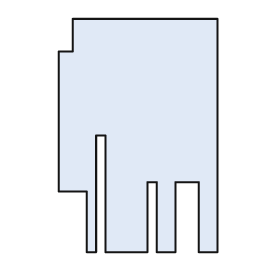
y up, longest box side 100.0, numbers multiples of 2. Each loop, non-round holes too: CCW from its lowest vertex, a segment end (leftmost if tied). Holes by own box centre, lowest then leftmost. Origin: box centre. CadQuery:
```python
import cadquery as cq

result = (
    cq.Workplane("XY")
    .moveTo(-22.0, -50.0)
    .lineTo(-18.0, -50.0)
    .lineTo(-18.0, 0.0)
    .lineTo(-14.0, 0.0)
    .lineTo(-14.0, -50.0)
    .lineTo(4.0, -50.0)
    .lineTo(4.0, -20.0)
    .lineTo(8.0, -20.0)
    .lineTo(8.0, -50.0)
    .lineTo(16.0, -50.0)
    .lineTo(16.0, -20.0)
    .lineTo(26.0, -20.0)
    .lineTo(26.0, -50.0)
    .lineTo(34.0, -50.0)
    .lineTo(34.0, 50.0)
    .lineTo(-28.0, 50.0)
    .lineTo(-28.0, 36.0)
    .lineTo(-34.0, 36.0)
    .lineTo(-34.0, -24.0)
    .lineTo(-22.0, -24.0)
    .close()
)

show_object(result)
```